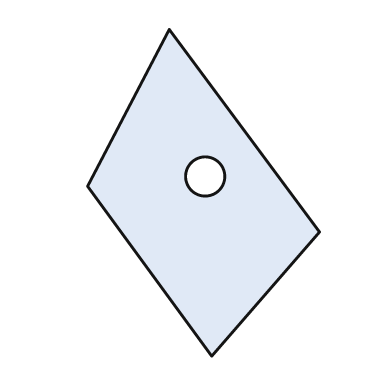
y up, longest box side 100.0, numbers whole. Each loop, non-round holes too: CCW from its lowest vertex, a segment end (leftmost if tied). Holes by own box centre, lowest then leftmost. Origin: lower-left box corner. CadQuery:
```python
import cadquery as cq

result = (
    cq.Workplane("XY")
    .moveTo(38.0, 0.0)
    .lineTo(71.0, 38.0)
    .lineTo(25.0, 100.0)
    .lineTo(0.0, 52.0)
    .close()
    .moveTo(36.0, 55.0)
    .circle(6.0)
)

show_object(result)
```